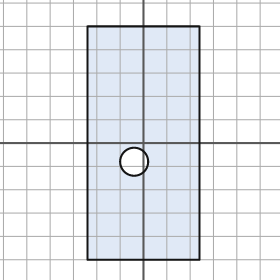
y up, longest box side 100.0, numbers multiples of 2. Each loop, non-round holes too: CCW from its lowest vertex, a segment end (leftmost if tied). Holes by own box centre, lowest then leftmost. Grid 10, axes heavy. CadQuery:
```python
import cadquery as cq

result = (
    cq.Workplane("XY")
    .moveTo(-24.0, -50.0)
    .lineTo(24.0, -50.0)
    .lineTo(24.0, 50.0)
    .lineTo(-24.0, 50.0)
    .close()
    .moveTo(-4.0, -8.0)
    .circle(6.0)
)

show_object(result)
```